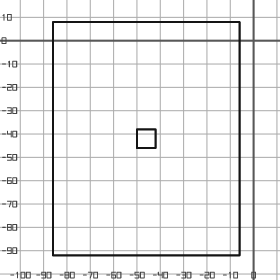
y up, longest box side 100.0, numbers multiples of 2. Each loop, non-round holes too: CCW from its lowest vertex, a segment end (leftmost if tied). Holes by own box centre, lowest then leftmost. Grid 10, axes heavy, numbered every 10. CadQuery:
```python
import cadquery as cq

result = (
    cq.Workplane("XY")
    .moveTo(-86.0, -92.0)
    .lineTo(-6.0, -92.0)
    .lineTo(-6.0, 8.0)
    .lineTo(-86.0, 8.0)
    .close()
    .moveTo(-50.0, -46.0)
    .lineTo(-42.0, -46.0)
    .lineTo(-42.0, -38.0)
    .lineTo(-50.0, -38.0)
    .close()
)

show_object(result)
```